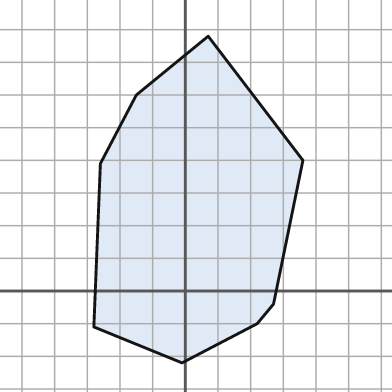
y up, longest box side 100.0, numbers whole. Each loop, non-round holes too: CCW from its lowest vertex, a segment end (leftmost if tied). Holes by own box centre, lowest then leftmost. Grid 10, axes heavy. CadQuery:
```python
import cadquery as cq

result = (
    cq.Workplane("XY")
    .moveTo(-1.0, -22.0)
    .lineTo(22.0, -10.0)
    .lineTo(27.0, -4.0)
    .lineTo(36.0, 40.0)
    .lineTo(7.0, 78.0)
    .lineTo(-15.0, 60.0)
    .lineTo(-26.0, 39.0)
    .lineTo(-28.0, -11.0)
    .close()
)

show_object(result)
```